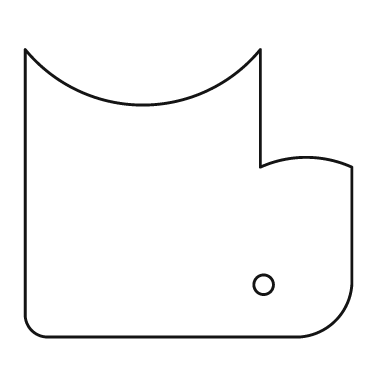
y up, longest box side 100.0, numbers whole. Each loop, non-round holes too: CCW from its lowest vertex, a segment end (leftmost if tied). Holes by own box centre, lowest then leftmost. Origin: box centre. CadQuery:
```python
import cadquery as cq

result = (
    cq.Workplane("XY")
    .moveTo(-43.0, -44.0)
    .lineTo(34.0, -44.0)
    .threePointArc((45.0, -39.0), (50.0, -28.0))
    .lineTo(50.0, 8.0)
    .threePointArc((36.0, 11.0), (22.0, 8.0))
    .lineTo(22.0, 44.0)
    .threePointArc((-14.0, 27.0), (-50.0, 44.0))
    .lineTo(-50.0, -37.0)
    .threePointArc((-48.0, -42.0), (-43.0, -44.0))
    .close()
    .moveTo(23.0, -28.0)
    .circle(3.0)
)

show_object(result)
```